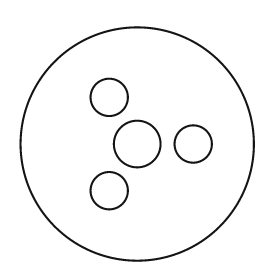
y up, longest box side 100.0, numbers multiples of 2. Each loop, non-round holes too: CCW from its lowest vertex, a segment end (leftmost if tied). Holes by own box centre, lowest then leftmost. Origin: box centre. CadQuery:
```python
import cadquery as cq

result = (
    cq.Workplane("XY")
    .moveTo(0.0, 0.0)
    .circle(50.0)
    .moveTo(-12.0, -20.0)
    .circle(8.0)
    .moveTo(0.0, 0.0)
    .circle(10.0)
    .moveTo(24.0, 0.0)
    .circle(8.0)
    .moveTo(-12.0, 20.0)
    .circle(8.0)
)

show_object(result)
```